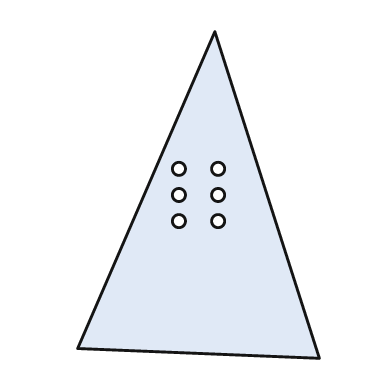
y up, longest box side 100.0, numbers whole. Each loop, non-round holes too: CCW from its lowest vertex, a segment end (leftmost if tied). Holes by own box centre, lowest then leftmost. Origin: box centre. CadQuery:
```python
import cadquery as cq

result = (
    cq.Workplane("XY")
    .moveTo(37.0, -50.0)
    .lineTo(5.0, 50.0)
    .lineTo(-37.0, -47.0)
    .close()
    .moveTo(-6.0, -8.0)
    .circle(2.0)
    .moveTo(6.0, -8.0)
    .circle(2.0)
    .moveTo(-6.0, 0.0)
    .circle(2.0)
    .moveTo(6.0, 0.0)
    .circle(2.0)
    .moveTo(-6.0, 8.0)
    .circle(2.0)
    .moveTo(6.0, 8.0)
    .circle(2.0)
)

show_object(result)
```